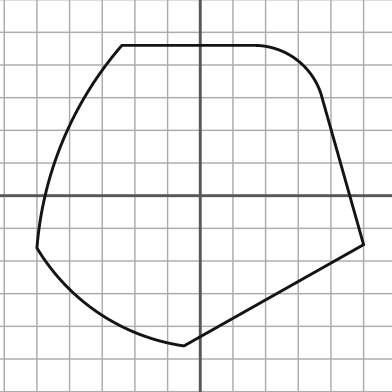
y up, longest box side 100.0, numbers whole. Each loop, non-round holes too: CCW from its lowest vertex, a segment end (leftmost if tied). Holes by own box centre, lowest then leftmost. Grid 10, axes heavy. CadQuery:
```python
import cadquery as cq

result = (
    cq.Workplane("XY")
    .moveTo(-5.0, -46.0)
    .lineTo(50.0, -15.0)
    .lineTo(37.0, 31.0)
    .threePointArc((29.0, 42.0), (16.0, 46.0))
    .lineTo(-24.0, 46.0)
    .threePointArc((-42.0, 17.0), (-50.0, -16.0))
    .threePointArc((-31.0, -36.0), (-5.0, -46.0))
    .close()
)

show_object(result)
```